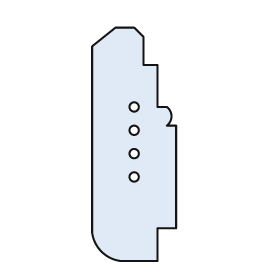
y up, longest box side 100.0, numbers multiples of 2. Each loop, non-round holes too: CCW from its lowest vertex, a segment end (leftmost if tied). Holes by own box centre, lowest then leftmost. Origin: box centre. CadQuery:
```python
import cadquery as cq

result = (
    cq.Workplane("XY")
    .moveTo(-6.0, -50.0)
    .lineTo(10.0, -50.0)
    .lineTo(10.0, -36.0)
    .lineTo(18.0, -36.0)
    .lineTo(18.0, 8.0)
    .lineTo(14.0, 8.0)
    .threePointArc((16.0, 12.0), (14.0, 16.0))
    .lineTo(10.0, 16.0)
    .lineTo(10.0, 34.0)
    .lineTo(4.0, 34.0)
    .lineTo(4.0, 46.0)
    .lineTo(0.0, 50.0)
    .lineTo(-8.0, 50.0)
    .lineTo(-18.0, 42.0)
    .lineTo(-18.0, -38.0)
    .threePointArc((-14.0, -46.0), (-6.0, -50.0))
    .close()
    .moveTo(0.0, -14.0)
    .circle(2.0)
    .moveTo(0.0, -4.0)
    .circle(2.0)
    .moveTo(0.0, 6.0)
    .circle(2.0)
    .moveTo(0.0, 16.0)
    .circle(2.0)
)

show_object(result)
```